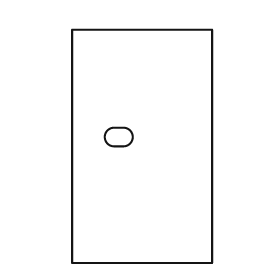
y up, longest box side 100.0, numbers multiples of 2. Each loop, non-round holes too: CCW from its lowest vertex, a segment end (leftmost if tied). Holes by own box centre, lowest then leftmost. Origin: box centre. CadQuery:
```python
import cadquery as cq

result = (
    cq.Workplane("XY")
    .moveTo(-30.0, -50.0)
    .lineTo(30.0, -50.0)
    .lineTo(30.0, 50.0)
    .lineTo(-30.0, 50.0)
    .close()
    .moveTo(-12.0, 0.0)
    .lineTo(-8.0, 0.0)
    .threePointArc((-4.0, 4.0), (-8.0, 8.0))
    .lineTo(-12.0, 8.0)
    .threePointArc((-16.0, 4.0), (-12.0, 0.0))
    .close()
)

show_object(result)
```